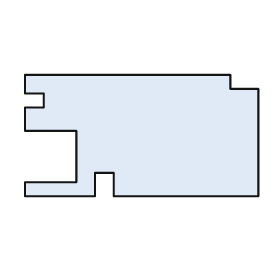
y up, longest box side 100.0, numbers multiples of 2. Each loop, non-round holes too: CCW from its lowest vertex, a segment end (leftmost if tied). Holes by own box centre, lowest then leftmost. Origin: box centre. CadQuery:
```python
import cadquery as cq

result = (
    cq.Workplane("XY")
    .moveTo(-50.0, -26.0)
    .lineTo(-20.0, -26.0)
    .lineTo(-20.0, -16.0)
    .lineTo(-12.0, -16.0)
    .lineTo(-12.0, -26.0)
    .lineTo(50.0, -26.0)
    .lineTo(50.0, 20.0)
    .lineTo(38.0, 20.0)
    .lineTo(38.0, 26.0)
    .lineTo(-50.0, 26.0)
    .lineTo(-50.0, 18.0)
    .lineTo(-42.0, 18.0)
    .lineTo(-42.0, 12.0)
    .lineTo(-50.0, 12.0)
    .lineTo(-50.0, 2.0)
    .lineTo(-28.0, 2.0)
    .lineTo(-28.0, -20.0)
    .lineTo(-50.0, -20.0)
    .close()
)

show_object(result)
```